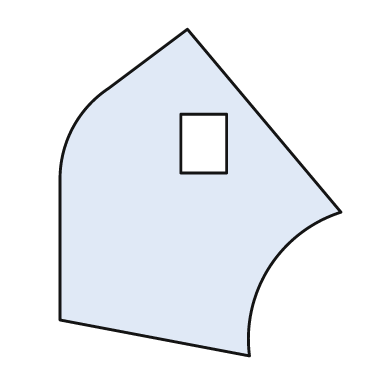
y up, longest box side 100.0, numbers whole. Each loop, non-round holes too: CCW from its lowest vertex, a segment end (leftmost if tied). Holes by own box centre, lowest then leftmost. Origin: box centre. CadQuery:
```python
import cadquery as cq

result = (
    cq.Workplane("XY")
    .moveTo(15.0, -50.0)
    .threePointArc((21.0, -23.0), (43.0, -6.0))
    .lineTo(-4.0, 50.0)
    .lineTo(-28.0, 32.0)
    .threePointArc((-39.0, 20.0), (-43.0, 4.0))
    .lineTo(-43.0, -39.0)
    .close()
    .moveTo(-6.0, 6.0)
    .lineTo(8.0, 6.0)
    .lineTo(8.0, 24.0)
    .lineTo(-6.0, 24.0)
    .close()
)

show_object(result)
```